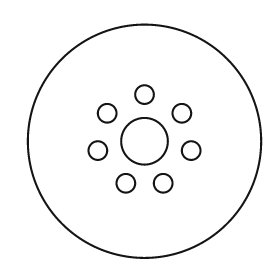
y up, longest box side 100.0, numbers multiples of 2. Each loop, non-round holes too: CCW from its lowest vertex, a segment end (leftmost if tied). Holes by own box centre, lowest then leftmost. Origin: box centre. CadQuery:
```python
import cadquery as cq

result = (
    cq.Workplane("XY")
    .moveTo(0.0, 0.0)
    .circle(50.0)
    .moveTo(-8.0, -18.0)
    .circle(4.0)
    .moveTo(8.0, -18.0)
    .circle(4.0)
    .moveTo(-20.0, -4.0)
    .circle(4.0)
    .moveTo(20.0, -4.0)
    .circle(4.0)
    .moveTo(0.0, 0.0)
    .circle(10.0)
    .moveTo(-16.0, 12.0)
    .circle(4.0)
    .moveTo(16.0, 12.0)
    .circle(4.0)
    .moveTo(0.0, 20.0)
    .circle(4.0)
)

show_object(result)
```